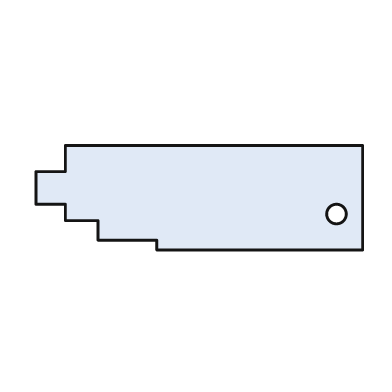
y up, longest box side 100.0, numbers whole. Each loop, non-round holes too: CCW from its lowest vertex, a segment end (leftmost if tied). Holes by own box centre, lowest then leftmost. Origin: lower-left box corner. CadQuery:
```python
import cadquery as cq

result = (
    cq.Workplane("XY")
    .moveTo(37.0, 0.0)
    .lineTo(100.0, 0.0)
    .lineTo(100.0, 32.0)
    .lineTo(9.0, 32.0)
    .lineTo(9.0, 24.0)
    .lineTo(0.0, 24.0)
    .lineTo(0.0, 14.0)
    .lineTo(9.0, 14.0)
    .lineTo(9.0, 9.0)
    .lineTo(19.0, 9.0)
    .lineTo(19.0, 3.0)
    .lineTo(37.0, 3.0)
    .close()
    .moveTo(92.0, 11.0)
    .circle(3.0)
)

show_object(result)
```